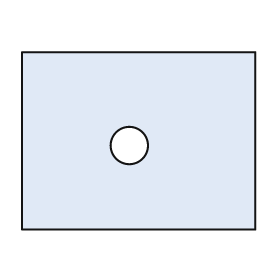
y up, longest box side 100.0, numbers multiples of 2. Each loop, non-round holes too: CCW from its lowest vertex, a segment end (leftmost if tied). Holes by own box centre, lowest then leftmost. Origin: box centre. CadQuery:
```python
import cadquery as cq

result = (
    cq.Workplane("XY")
    .moveTo(-50.0, -38.0)
    .lineTo(50.0, -38.0)
    .lineTo(50.0, 38.0)
    .lineTo(-50.0, 38.0)
    .close()
    .moveTo(-4.0, -2.0)
    .circle(8.0)
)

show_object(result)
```